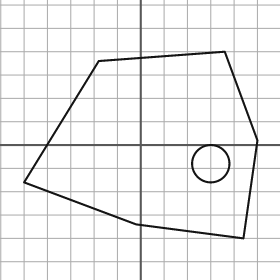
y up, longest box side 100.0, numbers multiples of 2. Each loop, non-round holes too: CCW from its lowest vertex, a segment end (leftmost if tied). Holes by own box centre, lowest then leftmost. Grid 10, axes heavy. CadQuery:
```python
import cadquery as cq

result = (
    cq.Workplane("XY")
    .moveTo(44.0, -40.0)
    .lineTo(50.0, 2.0)
    .lineTo(36.0, 40.0)
    .lineTo(-18.0, 36.0)
    .lineTo(-50.0, -16.0)
    .lineTo(-2.0, -34.0)
    .close()
    .moveTo(30.0, -8.0)
    .circle(8.0)
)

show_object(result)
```